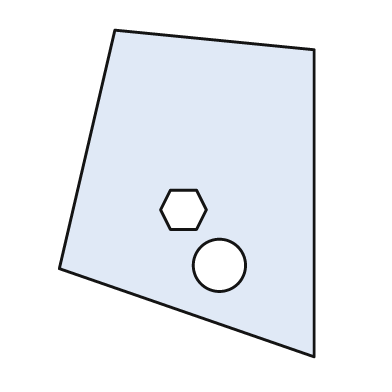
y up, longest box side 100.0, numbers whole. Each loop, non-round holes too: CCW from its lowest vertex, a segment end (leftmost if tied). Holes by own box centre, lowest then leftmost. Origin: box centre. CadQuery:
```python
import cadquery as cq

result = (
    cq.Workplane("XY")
    .moveTo(39.0, -50.0)
    .lineTo(39.0, 44.0)
    .lineTo(-22.0, 50.0)
    .lineTo(-39.0, -23.0)
    .close()
    .moveTo(10.0, -22.0)
    .circle(8.0)
    .moveTo(-5.0, -11.0)
    .lineTo(3.0, -11.0)
    .lineTo(6.0, -5.0)
    .lineTo(3.0, 1.0)
    .lineTo(-5.0, 1.0)
    .lineTo(-8.0, -5.0)
    .close()
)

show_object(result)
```